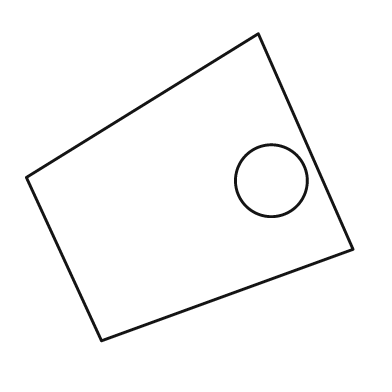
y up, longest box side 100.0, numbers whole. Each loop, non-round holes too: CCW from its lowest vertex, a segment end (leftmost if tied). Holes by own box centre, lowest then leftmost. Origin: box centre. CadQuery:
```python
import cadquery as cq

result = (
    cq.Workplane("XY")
    .moveTo(-27.0, -47.0)
    .lineTo(50.0, -19.0)
    .lineTo(21.0, 47.0)
    .lineTo(-50.0, 3.0)
    .close()
    .moveTo(25.0, 2.0)
    .circle(11.0)
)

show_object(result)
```